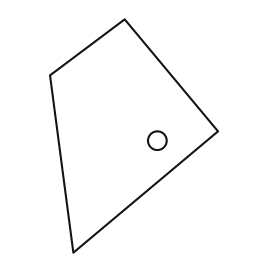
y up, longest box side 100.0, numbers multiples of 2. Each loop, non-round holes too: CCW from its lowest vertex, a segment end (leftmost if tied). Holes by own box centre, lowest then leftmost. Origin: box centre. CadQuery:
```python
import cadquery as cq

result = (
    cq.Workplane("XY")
    .moveTo(-26.0, -50.0)
    .lineTo(36.0, 2.0)
    .lineTo(-4.0, 50.0)
    .lineTo(-36.0, 26.0)
    .close()
    .moveTo(10.0, -2.0)
    .circle(4.0)
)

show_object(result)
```